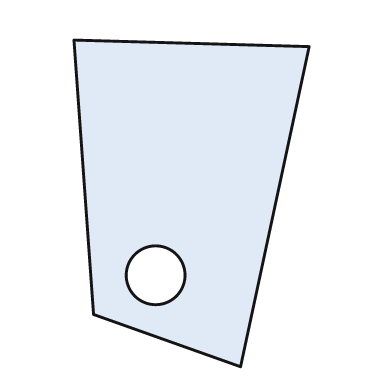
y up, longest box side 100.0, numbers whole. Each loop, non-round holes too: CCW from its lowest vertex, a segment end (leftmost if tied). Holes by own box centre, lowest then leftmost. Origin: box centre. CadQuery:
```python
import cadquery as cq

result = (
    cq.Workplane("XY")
    .moveTo(15.0, -50.0)
    .lineTo(36.0, 48.0)
    .lineTo(-36.0, 50.0)
    .lineTo(-30.0, -34.0)
    .close()
    .moveTo(-11.0, -22.0)
    .circle(9.0)
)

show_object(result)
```